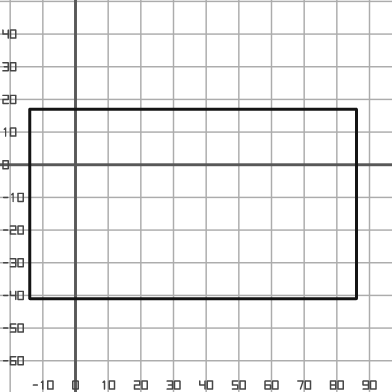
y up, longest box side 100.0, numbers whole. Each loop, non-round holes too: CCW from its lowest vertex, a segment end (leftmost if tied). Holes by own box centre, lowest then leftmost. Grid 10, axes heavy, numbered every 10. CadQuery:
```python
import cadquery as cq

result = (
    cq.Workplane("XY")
    .moveTo(-14.0, -41.0)
    .lineTo(86.0, -41.0)
    .lineTo(86.0, 17.0)
    .lineTo(-14.0, 17.0)
    .close()
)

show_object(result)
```